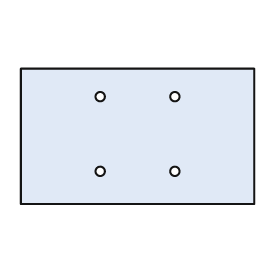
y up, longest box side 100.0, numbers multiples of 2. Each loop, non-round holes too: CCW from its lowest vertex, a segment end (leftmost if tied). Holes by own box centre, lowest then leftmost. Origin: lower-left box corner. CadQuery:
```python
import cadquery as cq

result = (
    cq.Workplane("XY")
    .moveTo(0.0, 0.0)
    .lineTo(100.0, 0.0)
    .lineTo(100.0, 58.0)
    .lineTo(0.0, 58.0)
    .close()
    .moveTo(34.0, 14.0)
    .circle(2.0)
    .moveTo(66.0, 14.0)
    .circle(2.0)
    .moveTo(34.0, 46.0)
    .circle(2.0)
    .moveTo(66.0, 46.0)
    .circle(2.0)
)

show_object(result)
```